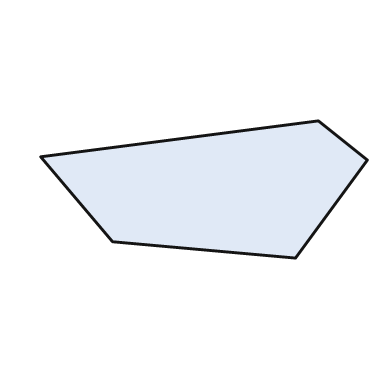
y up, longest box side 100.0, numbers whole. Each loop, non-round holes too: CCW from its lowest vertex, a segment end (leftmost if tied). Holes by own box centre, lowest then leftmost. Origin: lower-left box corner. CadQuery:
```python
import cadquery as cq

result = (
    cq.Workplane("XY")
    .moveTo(78.0, 0.0)
    .lineTo(100.0, 30.0)
    .lineTo(85.0, 42.0)
    .lineTo(0.0, 31.0)
    .lineTo(22.0, 5.0)
    .close()
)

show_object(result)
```